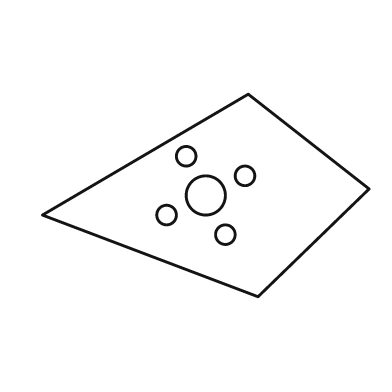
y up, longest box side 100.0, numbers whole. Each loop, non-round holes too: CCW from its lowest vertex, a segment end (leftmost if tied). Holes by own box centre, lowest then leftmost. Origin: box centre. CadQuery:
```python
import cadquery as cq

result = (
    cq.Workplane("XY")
    .moveTo(16.0, -31.0)
    .lineTo(50.0, 2.0)
    .lineTo(13.0, 31.0)
    .lineTo(-50.0, -6.0)
    .close()
    .moveTo(6.0, -12.0)
    .circle(3.0)
    .moveTo(-12.0, -6.0)
    .circle(3.0)
    .moveTo(0.0, 0.0)
    .circle(6.0)
    .moveTo(12.0, 6.0)
    .circle(3.0)
    .moveTo(-6.0, 12.0)
    .circle(3.0)
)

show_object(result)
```